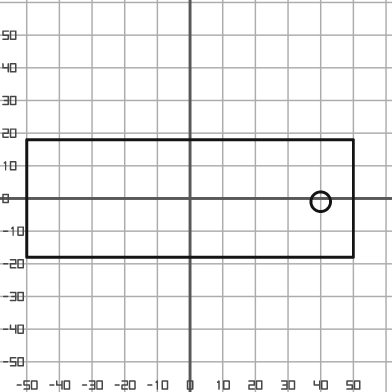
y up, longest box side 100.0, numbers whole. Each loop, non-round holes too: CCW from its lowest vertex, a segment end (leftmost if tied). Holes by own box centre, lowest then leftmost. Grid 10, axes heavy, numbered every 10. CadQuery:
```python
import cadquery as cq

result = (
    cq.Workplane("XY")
    .moveTo(-50.0, -18.0)
    .lineTo(50.0, -18.0)
    .lineTo(50.0, 18.0)
    .lineTo(-50.0, 18.0)
    .close()
    .moveTo(40.0, -1.0)
    .circle(3.0)
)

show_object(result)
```